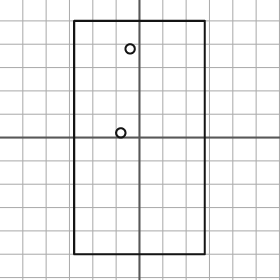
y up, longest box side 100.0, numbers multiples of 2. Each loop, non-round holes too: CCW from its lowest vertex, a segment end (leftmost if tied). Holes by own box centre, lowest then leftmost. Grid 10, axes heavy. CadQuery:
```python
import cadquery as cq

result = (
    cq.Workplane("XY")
    .moveTo(-28.0, -50.0)
    .lineTo(28.0, -50.0)
    .lineTo(28.0, 50.0)
    .lineTo(-28.0, 50.0)
    .close()
    .moveTo(-8.0, 2.0)
    .circle(2.0)
    .moveTo(-4.0, 38.0)
    .circle(2.0)
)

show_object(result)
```